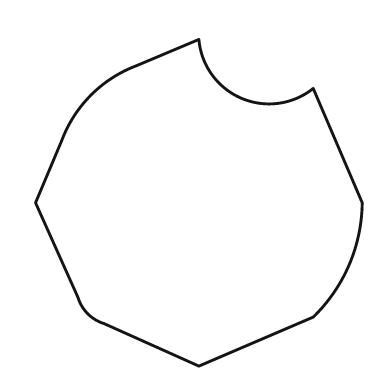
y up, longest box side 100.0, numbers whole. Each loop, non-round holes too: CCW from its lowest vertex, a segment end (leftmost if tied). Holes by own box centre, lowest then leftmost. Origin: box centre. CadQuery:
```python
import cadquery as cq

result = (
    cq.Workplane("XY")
    .moveTo(0.0, -50.0)
    .lineTo(35.0, -35.0)
    .threePointArc((46.0, -19.0), (50.0, 0.0))
    .lineTo(35.0, 35.0)
    .threePointArc((13.0, 32.0), (0.0, 50.0))
    .lineTo(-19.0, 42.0)
    .threePointArc((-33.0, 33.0), (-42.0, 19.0))
    .lineTo(-50.0, 0.0)
    .lineTo(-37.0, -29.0)
    .threePointArc((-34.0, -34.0), (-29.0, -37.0))
    .close()
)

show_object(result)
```